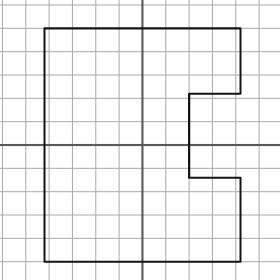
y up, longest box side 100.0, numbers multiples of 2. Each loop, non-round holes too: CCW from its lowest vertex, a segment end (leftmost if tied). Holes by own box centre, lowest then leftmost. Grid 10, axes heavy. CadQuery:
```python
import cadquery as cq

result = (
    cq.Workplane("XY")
    .moveTo(-42.0, -50.0)
    .lineTo(42.0, -50.0)
    .lineTo(42.0, -14.0)
    .lineTo(20.0, -14.0)
    .lineTo(20.0, 22.0)
    .lineTo(42.0, 22.0)
    .lineTo(42.0, 50.0)
    .lineTo(-42.0, 50.0)
    .close()
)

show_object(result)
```